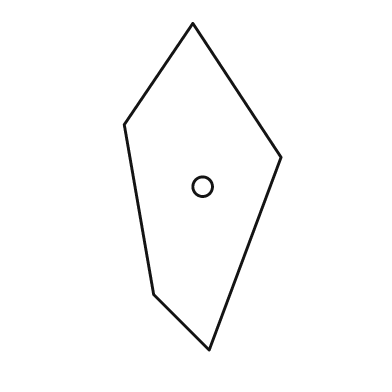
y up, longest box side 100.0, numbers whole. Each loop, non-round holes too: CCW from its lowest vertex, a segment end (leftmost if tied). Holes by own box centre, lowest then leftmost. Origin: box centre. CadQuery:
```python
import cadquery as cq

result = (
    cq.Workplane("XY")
    .moveTo(2.0, -50.0)
    .lineTo(24.0, 9.0)
    .lineTo(-3.0, 50.0)
    .lineTo(-24.0, 19.0)
    .lineTo(-15.0, -33.0)
    .close()
    .moveTo(0.0, 0.0)
    .circle(3.0)
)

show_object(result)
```